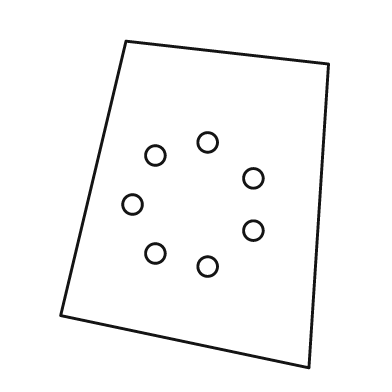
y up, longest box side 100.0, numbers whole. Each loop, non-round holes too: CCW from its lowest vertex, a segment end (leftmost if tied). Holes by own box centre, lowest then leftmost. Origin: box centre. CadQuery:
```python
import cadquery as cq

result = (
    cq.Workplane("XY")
    .moveTo(35.0, -50.0)
    .lineTo(41.0, 43.0)
    .lineTo(-21.0, 50.0)
    .lineTo(-41.0, -34.0)
    .close()
    .moveTo(4.0, -19.0)
    .circle(3.0)
    .moveTo(-12.0, -15.0)
    .circle(3.0)
    .moveTo(18.0, -8.0)
    .circle(3.0)
    .moveTo(-19.0, 0.0)
    .circle(3.0)
    .moveTo(18.0, 8.0)
    .circle(3.0)
    .moveTo(-12.0, 15.0)
    .circle(3.0)
    .moveTo(4.0, 19.0)
    .circle(3.0)
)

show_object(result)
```